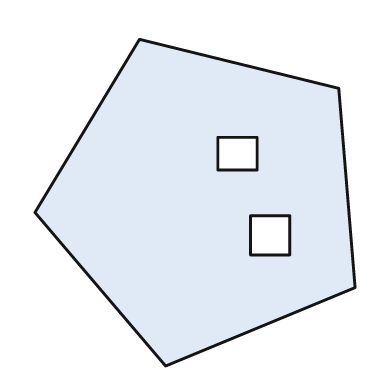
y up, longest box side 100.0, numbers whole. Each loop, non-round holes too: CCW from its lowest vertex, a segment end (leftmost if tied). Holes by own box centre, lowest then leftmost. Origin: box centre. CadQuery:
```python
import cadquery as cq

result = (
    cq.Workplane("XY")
    .moveTo(-9.0, -50.0)
    .lineTo(49.0, -26.0)
    .lineTo(44.0, 35.0)
    .lineTo(-17.0, 50.0)
    .lineTo(-49.0, -3.0)
    .close()
    .moveTo(17.0, -16.0)
    .lineTo(29.0, -16.0)
    .lineTo(29.0, -4.0)
    .lineTo(17.0, -4.0)
    .close()
    .moveTo(7.0, 10.0)
    .lineTo(19.0, 10.0)
    .lineTo(19.0, 20.0)
    .lineTo(7.0, 20.0)
    .close()
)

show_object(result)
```